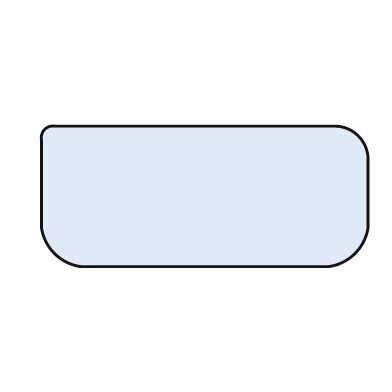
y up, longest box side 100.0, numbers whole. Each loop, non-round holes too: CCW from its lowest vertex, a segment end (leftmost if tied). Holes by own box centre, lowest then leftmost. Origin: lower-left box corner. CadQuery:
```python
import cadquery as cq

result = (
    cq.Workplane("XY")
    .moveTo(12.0, 0.0)
    .lineTo(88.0, 0.0)
    .threePointArc((96.0, 4.0), (100.0, 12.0))
    .lineTo(100.0, 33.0)
    .threePointArc((97.0, 40.0), (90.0, 43.0))
    .lineTo(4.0, 43.0)
    .threePointArc((1.0, 42.0), (0.0, 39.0))
    .lineTo(0.0, 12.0)
    .threePointArc((4.0, 4.0), (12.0, 0.0))
    .close()
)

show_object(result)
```